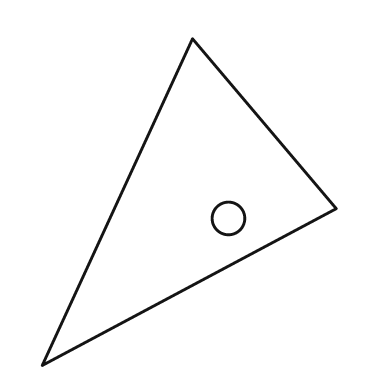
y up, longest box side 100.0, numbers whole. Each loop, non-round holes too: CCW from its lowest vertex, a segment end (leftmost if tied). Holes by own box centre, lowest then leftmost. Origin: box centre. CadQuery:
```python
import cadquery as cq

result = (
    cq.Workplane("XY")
    .moveTo(-45.0, -50.0)
    .lineTo(45.0, -2.0)
    .lineTo(1.0, 50.0)
    .close()
    .moveTo(12.0, -5.0)
    .circle(5.0)
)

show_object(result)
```